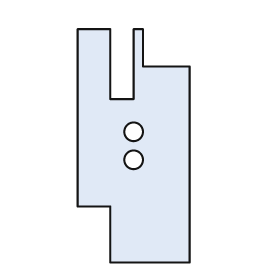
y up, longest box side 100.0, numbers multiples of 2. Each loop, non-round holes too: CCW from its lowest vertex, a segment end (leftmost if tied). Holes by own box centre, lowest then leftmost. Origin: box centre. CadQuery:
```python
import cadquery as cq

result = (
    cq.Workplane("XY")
    .moveTo(-10.0, -50.0)
    .lineTo(24.0, -50.0)
    .lineTo(24.0, 34.0)
    .lineTo(4.0, 34.0)
    .lineTo(4.0, 50.0)
    .lineTo(0.0, 50.0)
    .lineTo(0.0, 20.0)
    .lineTo(-10.0, 20.0)
    .lineTo(-10.0, 50.0)
    .lineTo(-24.0, 50.0)
    .lineTo(-24.0, -26.0)
    .lineTo(-10.0, -26.0)
    .close()
    .moveTo(0.0, -6.0)
    .circle(4.0)
    .moveTo(0.0, 6.0)
    .circle(4.0)
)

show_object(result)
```